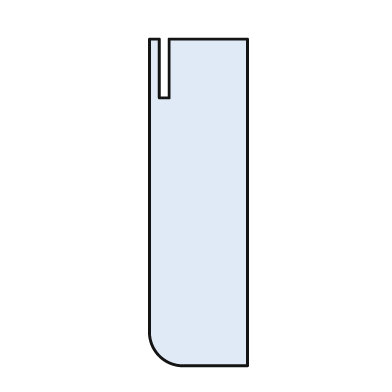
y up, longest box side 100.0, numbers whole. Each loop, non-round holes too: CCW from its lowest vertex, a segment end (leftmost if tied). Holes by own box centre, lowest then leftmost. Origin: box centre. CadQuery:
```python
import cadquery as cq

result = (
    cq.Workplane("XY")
    .moveTo(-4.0, -50.0)
    .lineTo(15.0, -50.0)
    .lineTo(15.0, 50.0)
    .lineTo(-9.0, 50.0)
    .lineTo(-9.0, 32.0)
    .lineTo(-12.0, 32.0)
    .lineTo(-12.0, 50.0)
    .lineTo(-15.0, 50.0)
    .lineTo(-15.0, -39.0)
    .threePointArc((-12.0, -47.0), (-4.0, -50.0))
    .close()
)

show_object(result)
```